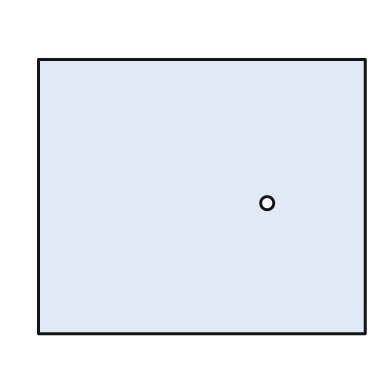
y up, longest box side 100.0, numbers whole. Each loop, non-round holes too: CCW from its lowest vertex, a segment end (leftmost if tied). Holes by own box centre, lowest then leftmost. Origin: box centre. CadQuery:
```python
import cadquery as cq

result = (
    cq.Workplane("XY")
    .moveTo(-50.0, -42.0)
    .lineTo(50.0, -42.0)
    .lineTo(50.0, 42.0)
    .lineTo(-50.0, 42.0)
    .close()
    .moveTo(20.0, -2.0)
    .circle(2.0)
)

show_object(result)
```